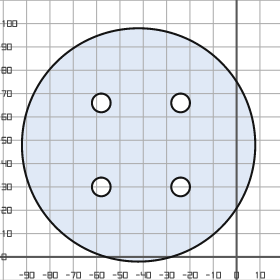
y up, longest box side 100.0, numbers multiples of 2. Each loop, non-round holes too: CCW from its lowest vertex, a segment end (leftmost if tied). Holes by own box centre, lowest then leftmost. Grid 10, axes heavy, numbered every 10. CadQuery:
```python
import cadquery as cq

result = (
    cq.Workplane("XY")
    .moveTo(-42.0, 48.0)
    .circle(50.0)
    .moveTo(-58.0, 30.0)
    .circle(4.0)
    .moveTo(-24.0, 30.0)
    .circle(4.0)
    .moveTo(-58.0, 66.0)
    .circle(4.0)
    .moveTo(-24.0, 66.0)
    .circle(4.0)
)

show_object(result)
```